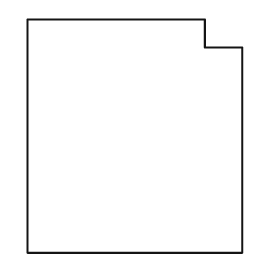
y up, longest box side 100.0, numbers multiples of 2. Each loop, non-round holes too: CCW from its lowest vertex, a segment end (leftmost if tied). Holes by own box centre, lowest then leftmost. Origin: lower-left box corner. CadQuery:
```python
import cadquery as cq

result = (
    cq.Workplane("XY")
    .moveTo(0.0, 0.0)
    .lineTo(92.0, 0.0)
    .lineTo(92.0, 88.0)
    .lineTo(76.0, 88.0)
    .lineTo(76.0, 100.0)
    .lineTo(0.0, 100.0)
    .close()
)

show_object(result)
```